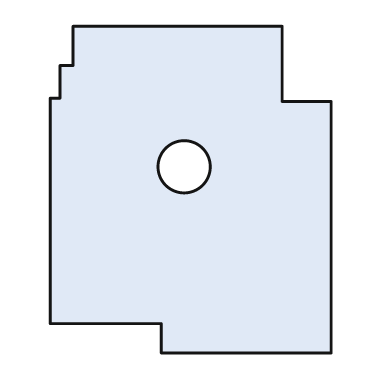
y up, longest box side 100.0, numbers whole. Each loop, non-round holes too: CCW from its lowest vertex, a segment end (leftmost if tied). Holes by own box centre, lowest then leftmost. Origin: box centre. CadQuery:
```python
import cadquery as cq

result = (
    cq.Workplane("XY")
    .moveTo(-9.0, -50.0)
    .lineTo(43.0, -50.0)
    .lineTo(43.0, 27.0)
    .lineTo(28.0, 27.0)
    .lineTo(28.0, 50.0)
    .lineTo(-36.0, 50.0)
    .lineTo(-36.0, 38.0)
    .lineTo(-40.0, 38.0)
    .lineTo(-40.0, 28.0)
    .lineTo(-43.0, 28.0)
    .lineTo(-43.0, -41.0)
    .lineTo(-9.0, -41.0)
    .close()
    .moveTo(-2.0, 7.0)
    .circle(8.0)
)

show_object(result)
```